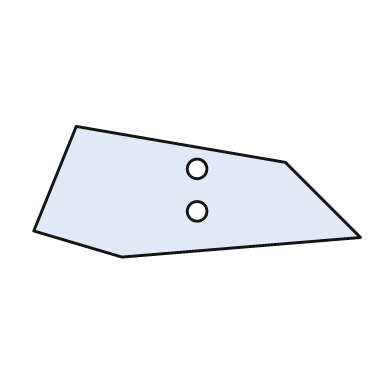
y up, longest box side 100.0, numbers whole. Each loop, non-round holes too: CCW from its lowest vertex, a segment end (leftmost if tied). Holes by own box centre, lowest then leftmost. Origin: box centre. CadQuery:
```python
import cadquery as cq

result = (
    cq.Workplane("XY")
    .moveTo(-23.0, -20.0)
    .lineTo(50.0, -14.0)
    .lineTo(27.0, 9.0)
    .lineTo(-37.0, 20.0)
    .lineTo(-50.0, -12.0)
    .close()
    .moveTo(0.0, -6.0)
    .circle(3.0)
    .moveTo(0.0, 7.0)
    .circle(3.0)
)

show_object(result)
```